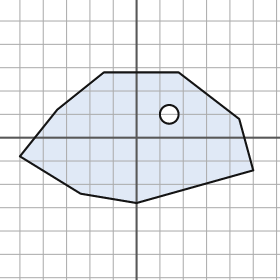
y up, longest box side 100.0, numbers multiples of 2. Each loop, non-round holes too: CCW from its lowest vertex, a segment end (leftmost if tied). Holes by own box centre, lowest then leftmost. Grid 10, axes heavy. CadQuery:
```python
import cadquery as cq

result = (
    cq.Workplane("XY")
    .moveTo(0.0, -28.0)
    .lineTo(50.0, -14.0)
    .lineTo(44.0, 8.0)
    .lineTo(18.0, 28.0)
    .lineTo(-14.0, 28.0)
    .lineTo(-34.0, 12.0)
    .lineTo(-50.0, -8.0)
    .lineTo(-24.0, -24.0)
    .close()
    .moveTo(14.0, 10.0)
    .circle(4.0)
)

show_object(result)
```